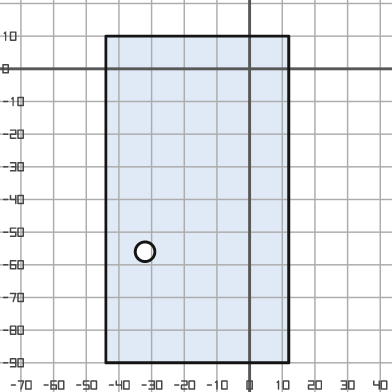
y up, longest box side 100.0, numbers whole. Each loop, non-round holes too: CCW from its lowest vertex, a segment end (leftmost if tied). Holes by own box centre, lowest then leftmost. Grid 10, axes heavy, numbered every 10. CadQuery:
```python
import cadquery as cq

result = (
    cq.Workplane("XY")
    .moveTo(-44.0, -90.0)
    .lineTo(12.0, -90.0)
    .lineTo(12.0, 10.0)
    .lineTo(-44.0, 10.0)
    .close()
    .moveTo(-32.0, -56.0)
    .circle(3.0)
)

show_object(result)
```